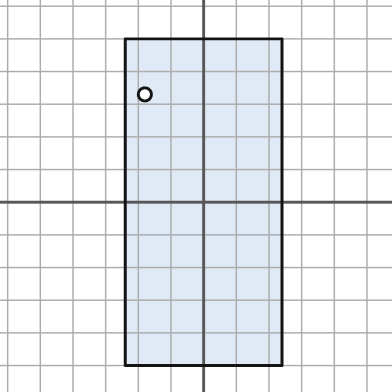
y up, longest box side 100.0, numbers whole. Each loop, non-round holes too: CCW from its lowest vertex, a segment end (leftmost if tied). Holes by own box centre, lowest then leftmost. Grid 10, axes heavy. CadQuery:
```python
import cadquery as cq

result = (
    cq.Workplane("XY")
    .moveTo(-24.0, -50.0)
    .lineTo(24.0, -50.0)
    .lineTo(24.0, 50.0)
    .lineTo(-24.0, 50.0)
    .close()
    .moveTo(-18.0, 33.0)
    .circle(2.0)
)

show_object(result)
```